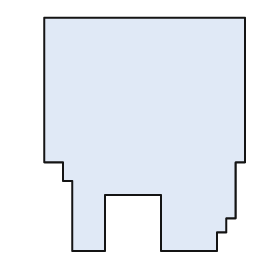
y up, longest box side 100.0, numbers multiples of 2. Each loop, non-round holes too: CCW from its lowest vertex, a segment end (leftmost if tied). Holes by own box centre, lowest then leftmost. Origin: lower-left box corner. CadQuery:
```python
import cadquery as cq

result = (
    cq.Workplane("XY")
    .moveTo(12.0, 0.0)
    .lineTo(26.0, 0.0)
    .lineTo(26.0, 24.0)
    .lineTo(50.0, 24.0)
    .lineTo(50.0, 0.0)
    .lineTo(74.0, 0.0)
    .lineTo(74.0, 8.0)
    .lineTo(78.0, 8.0)
    .lineTo(78.0, 14.0)
    .lineTo(82.0, 14.0)
    .lineTo(82.0, 38.0)
    .lineTo(86.0, 38.0)
    .lineTo(86.0, 100.0)
    .lineTo(0.0, 100.0)
    .lineTo(0.0, 38.0)
    .lineTo(8.0, 38.0)
    .lineTo(8.0, 30.0)
    .lineTo(12.0, 30.0)
    .close()
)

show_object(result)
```